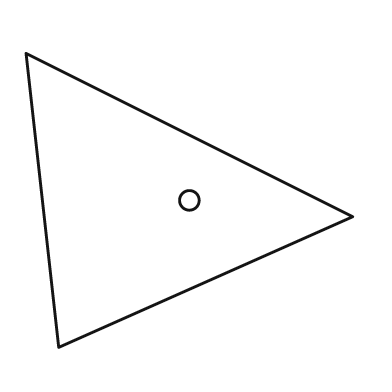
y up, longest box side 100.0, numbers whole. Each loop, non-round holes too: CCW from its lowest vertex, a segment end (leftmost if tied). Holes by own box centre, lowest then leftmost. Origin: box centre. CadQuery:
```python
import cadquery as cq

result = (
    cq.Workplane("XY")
    .moveTo(-40.0, -45.0)
    .lineTo(50.0, -5.0)
    .lineTo(-50.0, 45.0)
    .close()
    .moveTo(0.0, 0.0)
    .circle(3.0)
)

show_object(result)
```